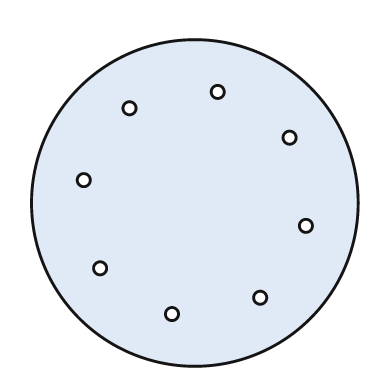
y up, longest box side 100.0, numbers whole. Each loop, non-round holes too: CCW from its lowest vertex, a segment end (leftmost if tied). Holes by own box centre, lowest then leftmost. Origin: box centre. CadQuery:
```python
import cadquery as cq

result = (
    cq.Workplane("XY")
    .moveTo(0.0, 0.0)
    .circle(50.0)
    .moveTo(-7.0, -34.0)
    .circle(2.0)
    .moveTo(20.0, -29.0)
    .circle(2.0)
    .moveTo(-29.0, -20.0)
    .circle(2.0)
    .moveTo(34.0, -7.0)
    .circle(2.0)
    .moveTo(-34.0, 7.0)
    .circle(2.0)
    .moveTo(29.0, 20.0)
    .circle(2.0)
    .moveTo(-20.0, 29.0)
    .circle(2.0)
    .moveTo(7.0, 34.0)
    .circle(2.0)
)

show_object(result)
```